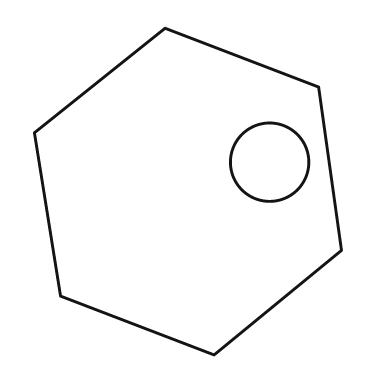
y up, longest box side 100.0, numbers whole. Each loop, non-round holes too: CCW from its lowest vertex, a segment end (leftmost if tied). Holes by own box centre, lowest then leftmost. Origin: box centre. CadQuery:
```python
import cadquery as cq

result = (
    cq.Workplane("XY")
    .moveTo(8.0, -50.0)
    .lineTo(47.0, -18.0)
    .lineTo(40.0, 32.0)
    .lineTo(-7.0, 50.0)
    .lineTo(-47.0, 18.0)
    .lineTo(-39.0, -32.0)
    .close()
    .moveTo(25.0, 9.0)
    .circle(12.0)
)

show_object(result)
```